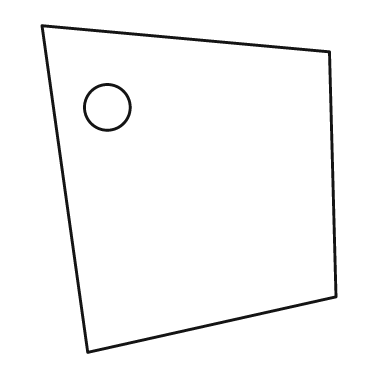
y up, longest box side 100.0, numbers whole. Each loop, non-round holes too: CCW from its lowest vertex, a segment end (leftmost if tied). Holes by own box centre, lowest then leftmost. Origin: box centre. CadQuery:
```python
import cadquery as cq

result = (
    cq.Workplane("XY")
    .moveTo(-31.0, -50.0)
    .lineTo(45.0, -33.0)
    .lineTo(43.0, 42.0)
    .lineTo(-45.0, 50.0)
    .close()
    .moveTo(-25.0, 25.0)
    .circle(7.0)
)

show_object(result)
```